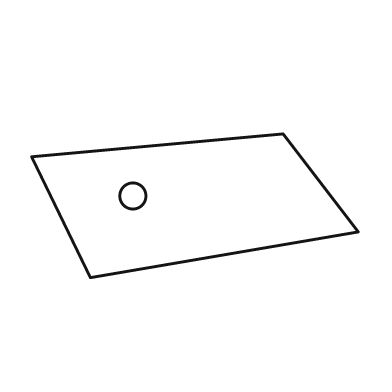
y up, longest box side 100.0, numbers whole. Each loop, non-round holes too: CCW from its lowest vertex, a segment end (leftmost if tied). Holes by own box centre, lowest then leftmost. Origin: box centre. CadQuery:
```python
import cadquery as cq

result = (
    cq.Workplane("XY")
    .moveTo(-32.0, -22.0)
    .lineTo(50.0, -8.0)
    .lineTo(27.0, 22.0)
    .lineTo(-50.0, 15.0)
    .close()
    .moveTo(-19.0, 3.0)
    .circle(4.0)
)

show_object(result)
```